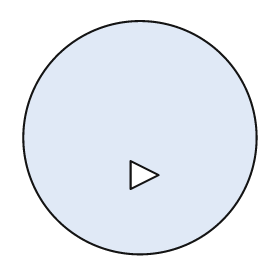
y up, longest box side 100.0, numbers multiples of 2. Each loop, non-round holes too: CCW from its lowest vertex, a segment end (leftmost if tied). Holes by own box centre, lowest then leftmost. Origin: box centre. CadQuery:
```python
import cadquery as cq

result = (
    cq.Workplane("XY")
    .moveTo(0.0, 0.0)
    .circle(50.0)
    .moveTo(-4.0, -22.0)
    .lineTo(8.0, -16.0)
    .lineTo(-4.0, -10.0)
    .close()
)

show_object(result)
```